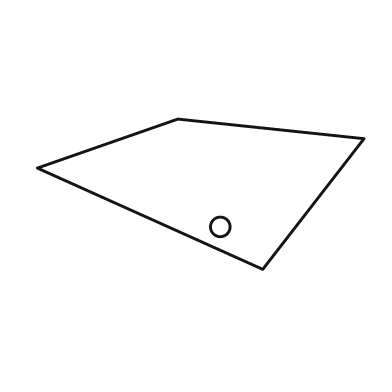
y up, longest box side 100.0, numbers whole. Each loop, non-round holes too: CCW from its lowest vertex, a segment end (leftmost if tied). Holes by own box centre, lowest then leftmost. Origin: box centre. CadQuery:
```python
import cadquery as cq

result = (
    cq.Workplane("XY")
    .moveTo(19.0, -23.0)
    .lineTo(50.0, 17.0)
    .lineTo(-7.0, 23.0)
    .lineTo(-50.0, 8.0)
    .close()
    .moveTo(6.0, -10.0)
    .circle(3.0)
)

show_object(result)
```